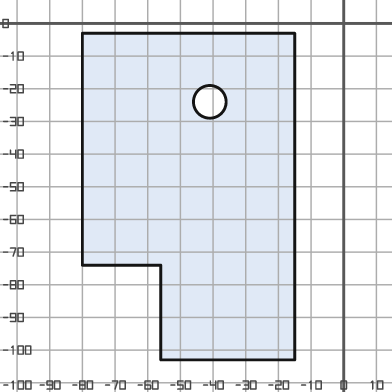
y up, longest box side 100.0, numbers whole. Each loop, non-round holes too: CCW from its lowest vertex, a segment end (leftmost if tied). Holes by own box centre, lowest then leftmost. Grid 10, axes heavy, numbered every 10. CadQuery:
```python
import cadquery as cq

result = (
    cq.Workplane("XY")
    .moveTo(-56.0, -103.0)
    .lineTo(-15.0, -103.0)
    .lineTo(-15.0, -3.0)
    .lineTo(-80.0, -3.0)
    .lineTo(-80.0, -74.0)
    .lineTo(-56.0, -74.0)
    .close()
    .moveTo(-41.0, -24.0)
    .circle(5.0)
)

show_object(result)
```